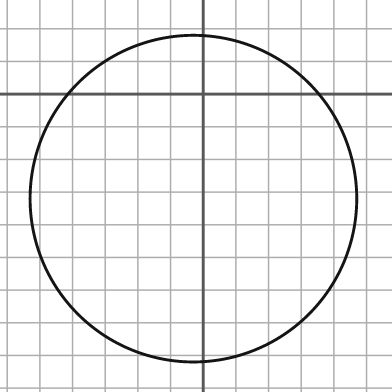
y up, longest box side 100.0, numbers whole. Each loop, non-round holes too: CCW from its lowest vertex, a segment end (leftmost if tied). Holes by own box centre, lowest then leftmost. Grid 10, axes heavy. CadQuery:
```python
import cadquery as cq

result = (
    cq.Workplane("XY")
    .moveTo(-3.0, -32.0)
    .circle(50.0)
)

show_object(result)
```